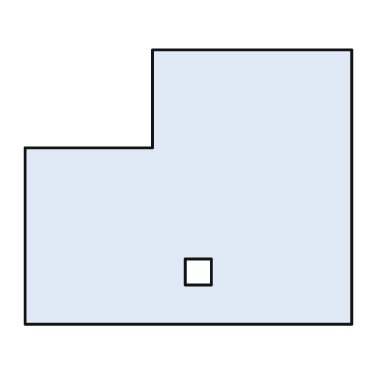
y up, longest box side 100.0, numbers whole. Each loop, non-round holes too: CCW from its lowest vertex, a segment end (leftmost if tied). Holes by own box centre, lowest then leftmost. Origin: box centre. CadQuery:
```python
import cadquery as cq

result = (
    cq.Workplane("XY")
    .moveTo(-50.0, -42.0)
    .lineTo(50.0, -42.0)
    .lineTo(50.0, 42.0)
    .lineTo(-11.0, 42.0)
    .lineTo(-11.0, 12.0)
    .lineTo(-50.0, 12.0)
    .close()
    .moveTo(-1.0, -30.0)
    .lineTo(7.0, -30.0)
    .lineTo(7.0, -22.0)
    .lineTo(-1.0, -22.0)
    .close()
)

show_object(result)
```